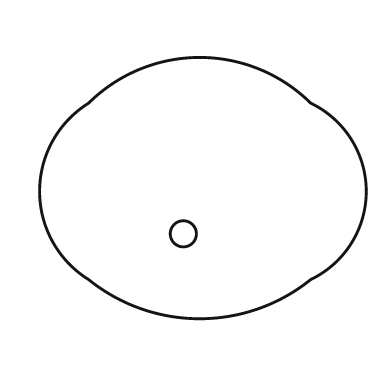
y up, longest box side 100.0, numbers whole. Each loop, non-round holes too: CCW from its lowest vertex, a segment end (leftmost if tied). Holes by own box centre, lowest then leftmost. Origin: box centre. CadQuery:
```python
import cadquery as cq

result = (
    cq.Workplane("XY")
    .moveTo(-35.0, -28.0)
    .threePointArc((-1.0, -40.0), (33.0, -28.0))
    .threePointArc((50.0, -1.0), (33.0, 26.0))
    .threePointArc((-1.0, 40.0), (-35.0, 26.0))
    .threePointArc((-50.0, -1.0), (-35.0, -28.0))
    .close()
    .moveTo(-6.0, -14.0)
    .circle(4.0)
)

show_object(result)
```